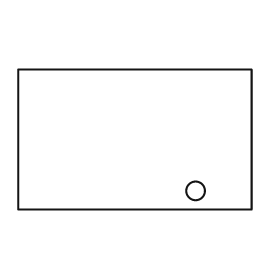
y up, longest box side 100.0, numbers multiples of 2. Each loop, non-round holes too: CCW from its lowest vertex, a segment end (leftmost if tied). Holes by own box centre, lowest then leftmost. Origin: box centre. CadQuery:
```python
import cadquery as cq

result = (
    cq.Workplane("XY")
    .moveTo(-50.0, -30.0)
    .lineTo(50.0, -30.0)
    .lineTo(50.0, 30.0)
    .lineTo(-50.0, 30.0)
    .close()
    .moveTo(26.0, -22.0)
    .circle(4.0)
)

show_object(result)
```